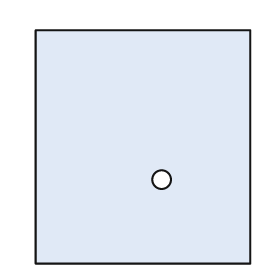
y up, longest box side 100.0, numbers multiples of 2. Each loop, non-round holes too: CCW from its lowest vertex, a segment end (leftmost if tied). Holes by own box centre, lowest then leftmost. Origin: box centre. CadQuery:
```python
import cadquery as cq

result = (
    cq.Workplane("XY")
    .moveTo(-46.0, -50.0)
    .lineTo(46.0, -50.0)
    .lineTo(46.0, 50.0)
    .lineTo(-46.0, 50.0)
    .close()
    .moveTo(8.0, -14.0)
    .circle(4.0)
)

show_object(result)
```